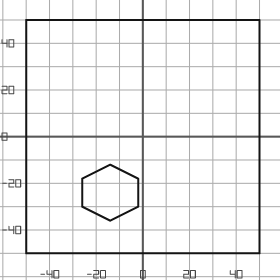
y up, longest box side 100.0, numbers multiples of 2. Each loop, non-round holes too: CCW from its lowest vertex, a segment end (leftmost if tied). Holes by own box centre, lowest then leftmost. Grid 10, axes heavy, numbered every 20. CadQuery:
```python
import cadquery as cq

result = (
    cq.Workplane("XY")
    .moveTo(-50.0, -50.0)
    .lineTo(50.0, -50.0)
    .lineTo(50.0, 50.0)
    .lineTo(-50.0, 50.0)
    .close()
    .moveTo(-14.0, -36.0)
    .lineTo(-2.0, -30.0)
    .lineTo(-2.0, -18.0)
    .lineTo(-14.0, -12.0)
    .lineTo(-26.0, -18.0)
    .lineTo(-26.0, -30.0)
    .close()
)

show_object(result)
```